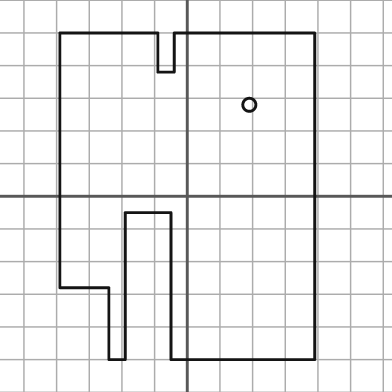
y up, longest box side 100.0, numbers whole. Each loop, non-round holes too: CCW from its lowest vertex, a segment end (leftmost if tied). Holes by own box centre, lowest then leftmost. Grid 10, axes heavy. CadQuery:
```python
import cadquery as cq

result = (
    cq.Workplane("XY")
    .moveTo(-24.0, -50.0)
    .lineTo(-19.0, -50.0)
    .lineTo(-19.0, -5.0)
    .lineTo(-5.0, -5.0)
    .lineTo(-5.0, -50.0)
    .lineTo(39.0, -50.0)
    .lineTo(39.0, 50.0)
    .lineTo(-4.0, 50.0)
    .lineTo(-4.0, 38.0)
    .lineTo(-9.0, 38.0)
    .lineTo(-9.0, 50.0)
    .lineTo(-39.0, 50.0)
    .lineTo(-39.0, -28.0)
    .lineTo(-24.0, -28.0)
    .close()
    .moveTo(19.0, 28.0)
    .circle(2.0)
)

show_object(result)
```